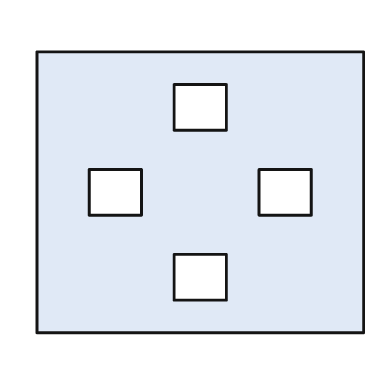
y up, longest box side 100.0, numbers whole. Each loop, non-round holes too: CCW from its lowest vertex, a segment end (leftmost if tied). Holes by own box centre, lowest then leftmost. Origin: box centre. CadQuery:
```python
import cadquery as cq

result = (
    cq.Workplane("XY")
    .moveTo(-50.0, -43.0)
    .lineTo(50.0, -43.0)
    .lineTo(50.0, 43.0)
    .lineTo(-50.0, 43.0)
    .close()
    .moveTo(-8.0, -33.0)
    .lineTo(8.0, -33.0)
    .lineTo(8.0, -19.0)
    .lineTo(-8.0, -19.0)
    .close()
    .moveTo(-34.0, -7.0)
    .lineTo(-18.0, -7.0)
    .lineTo(-18.0, 7.0)
    .lineTo(-34.0, 7.0)
    .close()
    .moveTo(18.0, -7.0)
    .lineTo(34.0, -7.0)
    .lineTo(34.0, 7.0)
    .lineTo(18.0, 7.0)
    .close()
    .moveTo(-8.0, 19.0)
    .lineTo(8.0, 19.0)
    .lineTo(8.0, 33.0)
    .lineTo(-8.0, 33.0)
    .close()
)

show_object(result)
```